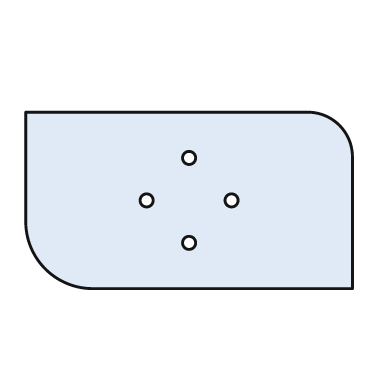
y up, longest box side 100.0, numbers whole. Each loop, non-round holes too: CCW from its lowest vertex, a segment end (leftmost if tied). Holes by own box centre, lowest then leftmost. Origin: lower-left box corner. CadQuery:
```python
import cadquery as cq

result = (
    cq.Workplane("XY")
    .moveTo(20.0, 0.0)
    .lineTo(100.0, 0.0)
    .lineTo(100.0, 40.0)
    .threePointArc((96.0, 50.0), (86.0, 54.0))
    .lineTo(0.0, 54.0)
    .lineTo(0.0, 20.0)
    .threePointArc((6.0, 6.0), (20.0, 0.0))
    .close()
    .moveTo(50.0, 14.0)
    .circle(2.0)
    .moveTo(37.0, 27.0)
    .circle(2.0)
    .moveTo(63.0, 27.0)
    .circle(2.0)
    .moveTo(50.0, 40.0)
    .circle(2.0)
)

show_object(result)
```